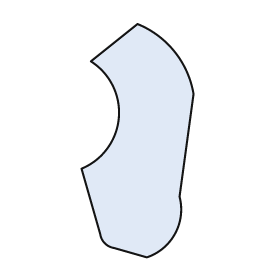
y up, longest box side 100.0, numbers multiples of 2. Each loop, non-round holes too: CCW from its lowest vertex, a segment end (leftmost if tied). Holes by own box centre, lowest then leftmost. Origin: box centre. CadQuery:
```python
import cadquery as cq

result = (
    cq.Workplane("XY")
    .moveTo(4.0, -50.0)
    .threePointArc((16.0, -40.0), (18.0, -24.0))
    .lineTo(24.0, 20.0)
    .threePointArc((16.0, 38.0), (0.0, 50.0))
    .lineTo(-20.0, 34.0)
    .threePointArc((-8.0, 10.0), (-24.0, -12.0))
    .lineTo(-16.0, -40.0)
    .threePointArc((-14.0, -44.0), (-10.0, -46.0))
    .close()
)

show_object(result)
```